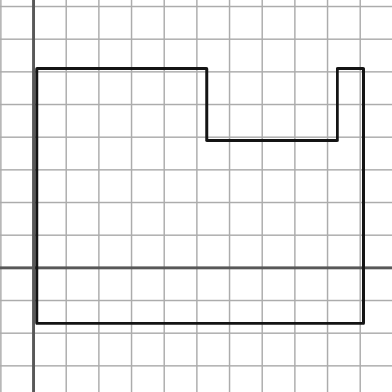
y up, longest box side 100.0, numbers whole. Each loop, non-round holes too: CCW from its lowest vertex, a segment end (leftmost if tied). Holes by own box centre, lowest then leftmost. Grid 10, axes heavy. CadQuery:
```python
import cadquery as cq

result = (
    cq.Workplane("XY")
    .moveTo(1.0, -17.0)
    .lineTo(101.0, -17.0)
    .lineTo(101.0, 61.0)
    .lineTo(93.0, 61.0)
    .lineTo(93.0, 39.0)
    .lineTo(53.0, 39.0)
    .lineTo(53.0, 61.0)
    .lineTo(1.0, 61.0)
    .close()
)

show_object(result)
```